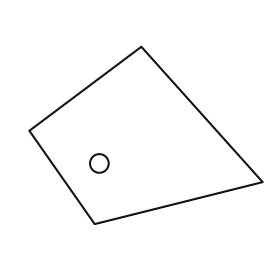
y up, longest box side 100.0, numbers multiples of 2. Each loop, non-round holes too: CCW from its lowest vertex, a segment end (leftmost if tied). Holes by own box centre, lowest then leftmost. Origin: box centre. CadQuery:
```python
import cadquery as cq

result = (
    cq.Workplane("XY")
    .moveTo(-22.0, -38.0)
    .lineTo(50.0, -20.0)
    .lineTo(-2.0, 38.0)
    .lineTo(-50.0, 2.0)
    .close()
    .moveTo(-20.0, -12.0)
    .circle(4.0)
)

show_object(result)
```